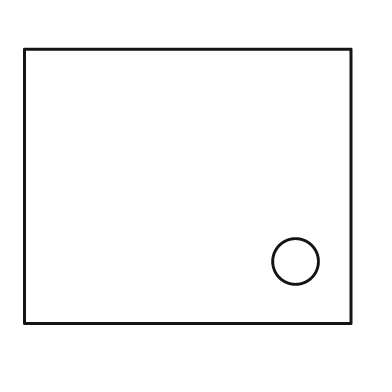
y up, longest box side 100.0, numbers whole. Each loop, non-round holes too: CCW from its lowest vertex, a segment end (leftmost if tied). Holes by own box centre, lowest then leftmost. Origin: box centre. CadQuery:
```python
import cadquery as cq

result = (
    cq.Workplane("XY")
    .moveTo(-50.0, -42.0)
    .lineTo(50.0, -42.0)
    .lineTo(50.0, 42.0)
    .lineTo(-50.0, 42.0)
    .close()
    .moveTo(33.0, -23.0)
    .circle(7.0)
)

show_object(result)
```